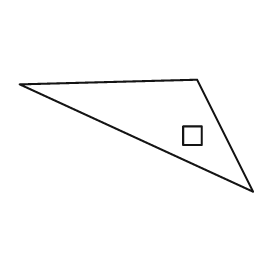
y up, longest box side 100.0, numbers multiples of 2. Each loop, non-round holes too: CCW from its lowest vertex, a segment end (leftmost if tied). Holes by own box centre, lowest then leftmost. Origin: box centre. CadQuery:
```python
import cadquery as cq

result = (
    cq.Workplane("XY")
    .moveTo(50.0, -24.0)
    .lineTo(26.0, 24.0)
    .lineTo(-50.0, 22.0)
    .close()
    .moveTo(20.0, -4.0)
    .lineTo(28.0, -4.0)
    .lineTo(28.0, 4.0)
    .lineTo(20.0, 4.0)
    .close()
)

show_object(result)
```